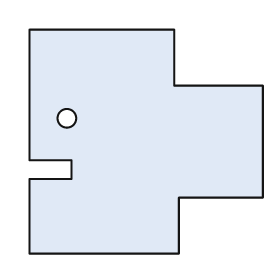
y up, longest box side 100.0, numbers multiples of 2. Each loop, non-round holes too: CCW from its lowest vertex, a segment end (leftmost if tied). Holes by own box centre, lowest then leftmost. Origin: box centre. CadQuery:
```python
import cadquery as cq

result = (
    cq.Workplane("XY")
    .moveTo(-50.0, -48.0)
    .lineTo(14.0, -48.0)
    .lineTo(14.0, -24.0)
    .lineTo(50.0, -24.0)
    .lineTo(50.0, 24.0)
    .lineTo(12.0, 24.0)
    .lineTo(12.0, 48.0)
    .lineTo(-50.0, 48.0)
    .lineTo(-50.0, -8.0)
    .lineTo(-32.0, -8.0)
    .lineTo(-32.0, -16.0)
    .lineTo(-50.0, -16.0)
    .close()
    .moveTo(-34.0, 10.0)
    .circle(4.0)
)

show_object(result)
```